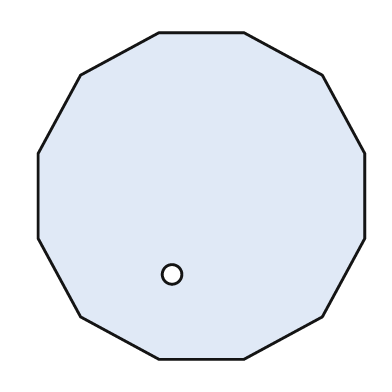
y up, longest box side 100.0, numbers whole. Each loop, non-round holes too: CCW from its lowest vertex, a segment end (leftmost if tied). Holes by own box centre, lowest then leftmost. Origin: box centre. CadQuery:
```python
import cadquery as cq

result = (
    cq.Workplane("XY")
    .moveTo(-13.0, -50.0)
    .lineTo(13.0, -50.0)
    .lineTo(37.0, -37.0)
    .lineTo(50.0, -13.0)
    .lineTo(50.0, 13.0)
    .lineTo(37.0, 37.0)
    .lineTo(13.0, 50.0)
    .lineTo(-13.0, 50.0)
    .lineTo(-37.0, 37.0)
    .lineTo(-50.0, 13.0)
    .lineTo(-50.0, -13.0)
    .lineTo(-37.0, -37.0)
    .close()
    .moveTo(-9.0, -24.0)
    .circle(3.0)
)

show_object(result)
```